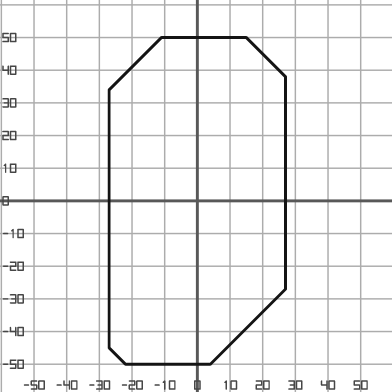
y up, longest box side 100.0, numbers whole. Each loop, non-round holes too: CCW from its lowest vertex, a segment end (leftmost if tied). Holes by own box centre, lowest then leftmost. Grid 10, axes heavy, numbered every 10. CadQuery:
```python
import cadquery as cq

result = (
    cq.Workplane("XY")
    .moveTo(-22.0, -50.0)
    .lineTo(4.0, -50.0)
    .lineTo(27.0, -27.0)
    .lineTo(27.0, 38.0)
    .lineTo(15.0, 50.0)
    .lineTo(-11.0, 50.0)
    .lineTo(-27.0, 34.0)
    .lineTo(-27.0, -45.0)
    .close()
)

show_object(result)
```